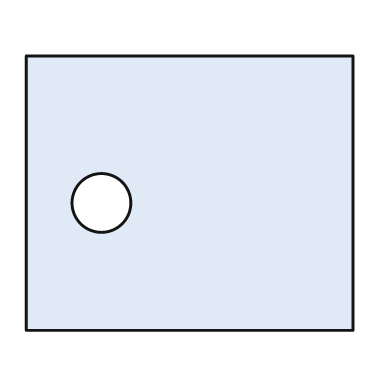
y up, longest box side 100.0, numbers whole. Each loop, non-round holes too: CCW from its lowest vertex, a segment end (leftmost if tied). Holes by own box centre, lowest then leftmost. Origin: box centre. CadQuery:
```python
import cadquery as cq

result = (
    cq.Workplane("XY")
    .moveTo(-50.0, -42.0)
    .lineTo(50.0, -42.0)
    .lineTo(50.0, 42.0)
    .lineTo(-50.0, 42.0)
    .close()
    .moveTo(-27.0, -3.0)
    .circle(9.0)
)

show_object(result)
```